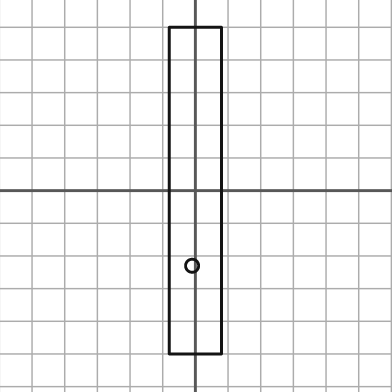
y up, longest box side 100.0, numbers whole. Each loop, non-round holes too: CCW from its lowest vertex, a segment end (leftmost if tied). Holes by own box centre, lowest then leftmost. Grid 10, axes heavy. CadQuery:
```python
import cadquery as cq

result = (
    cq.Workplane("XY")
    .moveTo(-8.0, -50.0)
    .lineTo(8.0, -50.0)
    .lineTo(8.0, 50.0)
    .lineTo(-8.0, 50.0)
    .close()
    .moveTo(-1.0, -23.0)
    .circle(2.0)
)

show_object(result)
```